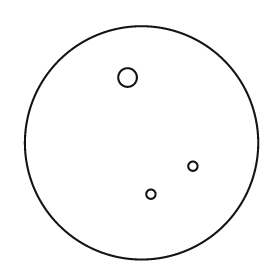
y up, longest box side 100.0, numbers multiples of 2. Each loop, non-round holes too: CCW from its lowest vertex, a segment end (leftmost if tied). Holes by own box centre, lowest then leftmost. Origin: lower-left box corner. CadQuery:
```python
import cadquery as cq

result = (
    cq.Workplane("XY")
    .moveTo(50.0, 50.0)
    .circle(50.0)
    .moveTo(54.0, 28.0)
    .circle(2.0)
    .moveTo(72.0, 40.0)
    .circle(2.0)
    .moveTo(44.0, 78.0)
    .circle(4.0)
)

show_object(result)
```